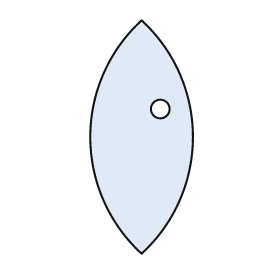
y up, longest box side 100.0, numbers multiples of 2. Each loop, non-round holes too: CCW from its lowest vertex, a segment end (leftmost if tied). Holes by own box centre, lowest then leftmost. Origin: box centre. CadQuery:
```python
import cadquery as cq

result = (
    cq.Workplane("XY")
    .moveTo(0.0, -50.0)
    .threePointArc((22.0, 0.0), (0.0, 50.0))
    .threePointArc((-22.0, 0.0), (0.0, -50.0))
    .close()
    .moveTo(8.0, 12.0)
    .circle(4.0)
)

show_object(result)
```